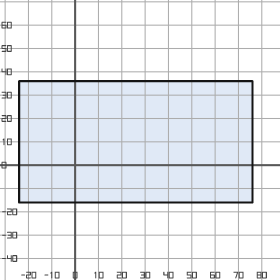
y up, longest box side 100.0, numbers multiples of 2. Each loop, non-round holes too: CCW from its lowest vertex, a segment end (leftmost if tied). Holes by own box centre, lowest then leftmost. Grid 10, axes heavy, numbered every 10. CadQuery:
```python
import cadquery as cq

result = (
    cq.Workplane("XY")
    .moveTo(-24.0, -16.0)
    .lineTo(76.0, -16.0)
    .lineTo(76.0, 36.0)
    .lineTo(-24.0, 36.0)
    .close()
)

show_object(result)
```